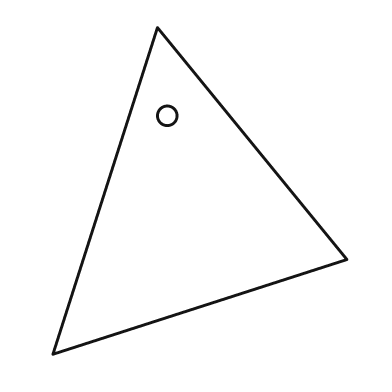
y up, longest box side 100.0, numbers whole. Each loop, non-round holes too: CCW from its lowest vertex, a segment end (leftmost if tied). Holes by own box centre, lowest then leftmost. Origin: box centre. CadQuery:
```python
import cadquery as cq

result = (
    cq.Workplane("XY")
    .moveTo(-45.0, -50.0)
    .lineTo(45.0, -21.0)
    .lineTo(-13.0, 50.0)
    .close()
    .moveTo(-10.0, 23.0)
    .circle(3.0)
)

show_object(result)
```